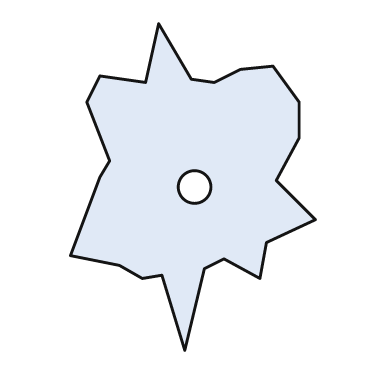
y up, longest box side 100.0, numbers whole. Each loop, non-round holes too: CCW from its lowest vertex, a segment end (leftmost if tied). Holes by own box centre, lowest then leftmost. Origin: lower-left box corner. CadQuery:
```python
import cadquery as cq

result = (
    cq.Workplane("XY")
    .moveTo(35.0, 0.0)
    .lineTo(41.0, 25.0)
    .lineTo(47.0, 28.0)
    .lineTo(58.0, 22.0)
    .lineTo(60.0, 33.0)
    .lineTo(75.0, 40.0)
    .lineTo(63.0, 52.0)
    .lineTo(70.0, 65.0)
    .lineTo(70.0, 76.0)
    .lineTo(62.0, 87.0)
    .lineTo(52.0, 86.0)
    .lineTo(44.0, 82.0)
    .lineTo(37.0, 83.0)
    .lineTo(27.0, 100.0)
    .lineTo(23.0, 82.0)
    .lineTo(9.0, 84.0)
    .lineTo(5.0, 76.0)
    .lineTo(12.0, 58.0)
    .lineTo(9.0, 53.0)
    .lineTo(0.0, 29.0)
    .lineTo(15.0, 26.0)
    .lineTo(22.0, 22.0)
    .lineTo(28.0, 23.0)
    .close()
    .moveTo(38.0, 50.0)
    .circle(5.0)
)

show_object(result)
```